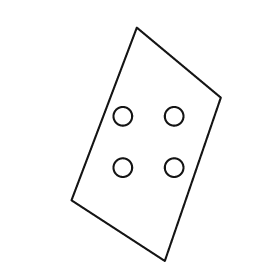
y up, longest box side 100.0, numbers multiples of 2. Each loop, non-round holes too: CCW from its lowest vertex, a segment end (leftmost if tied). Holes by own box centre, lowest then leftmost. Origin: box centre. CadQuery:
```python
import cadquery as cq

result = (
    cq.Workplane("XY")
    .moveTo(8.0, -50.0)
    .lineTo(32.0, 20.0)
    .lineTo(-4.0, 50.0)
    .lineTo(-32.0, -24.0)
    .close()
    .moveTo(-10.0, -10.0)
    .circle(4.0)
    .moveTo(12.0, -10.0)
    .circle(4.0)
    .moveTo(-10.0, 12.0)
    .circle(4.0)
    .moveTo(12.0, 12.0)
    .circle(4.0)
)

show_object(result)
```